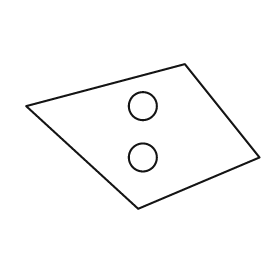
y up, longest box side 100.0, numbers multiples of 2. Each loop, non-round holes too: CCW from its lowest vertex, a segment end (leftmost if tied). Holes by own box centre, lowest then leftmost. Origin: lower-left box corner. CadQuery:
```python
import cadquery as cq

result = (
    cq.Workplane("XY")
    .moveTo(48.0, 0.0)
    .lineTo(100.0, 22.0)
    .lineTo(68.0, 62.0)
    .lineTo(0.0, 44.0)
    .close()
    .moveTo(50.0, 22.0)
    .circle(6.0)
    .moveTo(50.0, 44.0)
    .circle(6.0)
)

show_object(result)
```